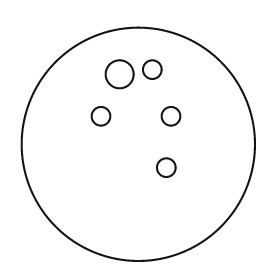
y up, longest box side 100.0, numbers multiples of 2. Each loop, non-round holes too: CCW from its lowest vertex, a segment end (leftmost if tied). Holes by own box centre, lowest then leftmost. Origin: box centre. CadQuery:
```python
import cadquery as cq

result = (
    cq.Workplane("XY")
    .moveTo(0.0, 0.0)
    .circle(50.0)
    .moveTo(12.0, -10.0)
    .circle(4.0)
    .moveTo(-16.0, 12.0)
    .circle(4.0)
    .moveTo(14.0, 12.0)
    .circle(4.0)
    .moveTo(-8.0, 30.0)
    .circle(6.0)
    .moveTo(6.0, 32.0)
    .circle(4.0)
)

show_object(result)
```